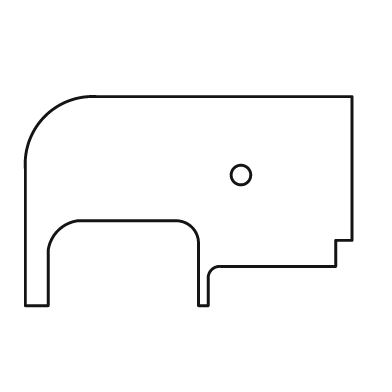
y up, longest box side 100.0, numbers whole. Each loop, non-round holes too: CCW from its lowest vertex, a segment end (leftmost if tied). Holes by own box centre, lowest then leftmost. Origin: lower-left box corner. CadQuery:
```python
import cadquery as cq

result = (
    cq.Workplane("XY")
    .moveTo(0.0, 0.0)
    .lineTo(7.0, 0.0)
    .lineTo(7.0, 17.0)
    .threePointArc((10.0, 23.0), (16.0, 26.0))
    .lineTo(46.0, 26.0)
    .threePointArc((51.0, 24.0), (53.0, 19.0))
    .lineTo(53.0, 0.0)
    .lineTo(56.0, 0.0)
    .lineTo(56.0, 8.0)
    .threePointArc((57.0, 11.0), (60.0, 12.0))
    .lineTo(95.0, 12.0)
    .lineTo(95.0, 20.0)
    .lineTo(100.0, 20.0)
    .lineTo(100.0, 64.0)
    .lineTo(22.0, 64.0)
    .threePointArc((6.0, 58.0), (0.0, 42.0))
    .close()
    .moveTo(66.0, 40.0)
    .circle(3.0)
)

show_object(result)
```